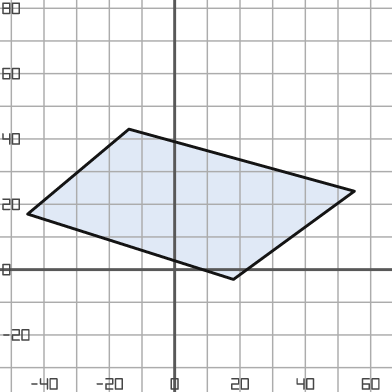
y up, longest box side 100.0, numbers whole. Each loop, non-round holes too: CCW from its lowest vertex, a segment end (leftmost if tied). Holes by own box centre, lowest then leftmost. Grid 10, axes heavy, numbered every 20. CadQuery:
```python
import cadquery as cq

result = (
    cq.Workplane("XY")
    .moveTo(18.0, -3.0)
    .lineTo(55.0, 24.0)
    .lineTo(-14.0, 43.0)
    .lineTo(-45.0, 17.0)
    .close()
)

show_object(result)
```